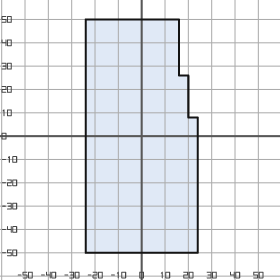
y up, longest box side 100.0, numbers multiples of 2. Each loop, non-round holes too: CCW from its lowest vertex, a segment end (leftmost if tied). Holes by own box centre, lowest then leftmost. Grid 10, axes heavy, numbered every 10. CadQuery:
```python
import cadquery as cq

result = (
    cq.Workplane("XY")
    .moveTo(-24.0, -50.0)
    .lineTo(24.0, -50.0)
    .lineTo(24.0, 8.0)
    .lineTo(20.0, 8.0)
    .lineTo(20.0, 26.0)
    .lineTo(16.0, 26.0)
    .lineTo(16.0, 50.0)
    .lineTo(-24.0, 50.0)
    .close()
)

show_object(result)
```